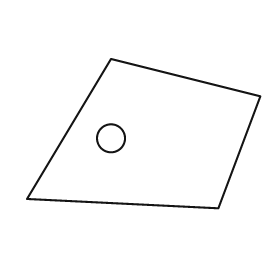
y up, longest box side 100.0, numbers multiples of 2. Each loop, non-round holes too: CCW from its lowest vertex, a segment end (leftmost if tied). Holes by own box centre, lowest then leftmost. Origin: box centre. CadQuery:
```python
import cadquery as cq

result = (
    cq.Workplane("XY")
    .moveTo(32.0, -32.0)
    .lineTo(50.0, 16.0)
    .lineTo(-14.0, 32.0)
    .lineTo(-50.0, -28.0)
    .close()
    .moveTo(-14.0, -2.0)
    .circle(6.0)
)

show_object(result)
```